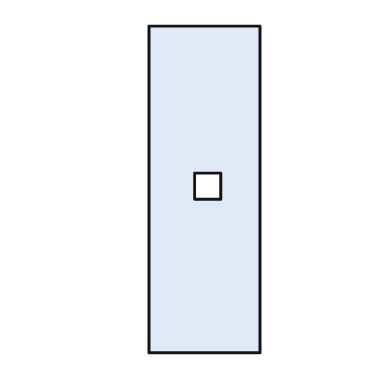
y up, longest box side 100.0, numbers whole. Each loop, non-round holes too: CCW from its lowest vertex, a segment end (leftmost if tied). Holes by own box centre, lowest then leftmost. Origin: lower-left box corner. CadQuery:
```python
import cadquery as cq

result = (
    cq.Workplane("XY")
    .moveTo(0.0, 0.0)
    .lineTo(34.0, 0.0)
    .lineTo(34.0, 100.0)
    .lineTo(0.0, 100.0)
    .close()
    .moveTo(14.0, 47.0)
    .lineTo(22.0, 47.0)
    .lineTo(22.0, 55.0)
    .lineTo(14.0, 55.0)
    .close()
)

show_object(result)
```